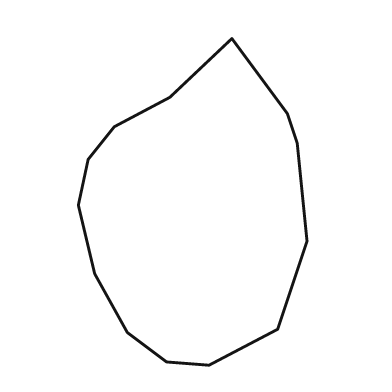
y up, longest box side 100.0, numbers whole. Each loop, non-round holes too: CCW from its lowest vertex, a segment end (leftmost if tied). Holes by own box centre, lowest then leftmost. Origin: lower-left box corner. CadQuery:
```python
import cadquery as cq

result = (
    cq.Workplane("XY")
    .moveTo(40.0, 0.0)
    .lineTo(61.0, 11.0)
    .lineTo(70.0, 38.0)
    .lineTo(67.0, 68.0)
    .lineTo(64.0, 77.0)
    .lineTo(47.0, 100.0)
    .lineTo(28.0, 82.0)
    .lineTo(11.0, 73.0)
    .lineTo(3.0, 63.0)
    .lineTo(0.0, 49.0)
    .lineTo(5.0, 28.0)
    .lineTo(15.0, 10.0)
    .lineTo(27.0, 1.0)
    .close()
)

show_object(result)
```